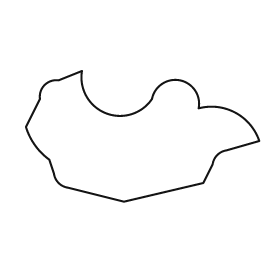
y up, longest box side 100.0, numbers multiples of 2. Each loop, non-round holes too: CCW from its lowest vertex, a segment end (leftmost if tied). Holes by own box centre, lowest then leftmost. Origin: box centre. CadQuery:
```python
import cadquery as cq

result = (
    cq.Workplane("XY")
    .moveTo(-8.0, -28.0)
    .lineTo(26.0, -20.0)
    .lineTo(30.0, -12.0)
    .threePointArc((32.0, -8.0), (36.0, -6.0))
    .lineTo(50.0, -2.0)
    .threePointArc((40.0, 10.0), (24.0, 12.0))
    .threePointArc((16.0, 24.0), (4.0, 16.0))
    .threePointArc((-16.0, 10.0), (-26.0, 28.0))
    .lineTo(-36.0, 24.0)
    .threePointArc((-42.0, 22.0), (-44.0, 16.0))
    .lineTo(-50.0, 4.0)
    .threePointArc((-46.0, -4.0), (-40.0, -10.0))
    .lineTo(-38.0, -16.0)
    .threePointArc((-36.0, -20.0), (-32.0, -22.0))
    .close()
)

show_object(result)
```